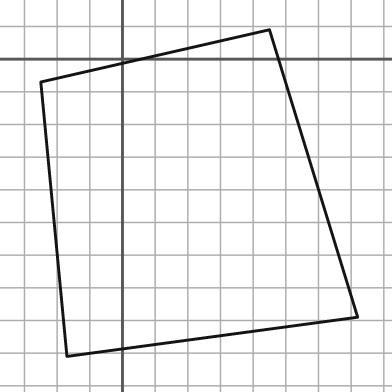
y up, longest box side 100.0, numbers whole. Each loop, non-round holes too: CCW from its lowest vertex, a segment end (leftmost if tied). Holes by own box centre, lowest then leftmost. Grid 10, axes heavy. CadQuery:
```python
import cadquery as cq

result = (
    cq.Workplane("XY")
    .moveTo(-17.0, -91.0)
    .lineTo(72.0, -79.0)
    .lineTo(45.0, 9.0)
    .lineTo(-25.0, -7.0)
    .close()
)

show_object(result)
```